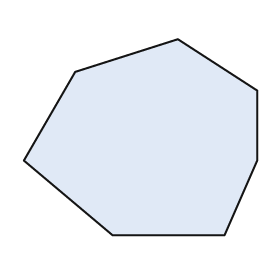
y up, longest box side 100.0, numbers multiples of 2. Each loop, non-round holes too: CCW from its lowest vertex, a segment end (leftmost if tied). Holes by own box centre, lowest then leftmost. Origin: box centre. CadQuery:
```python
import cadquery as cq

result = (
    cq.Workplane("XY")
    .moveTo(-12.0, -42.0)
    .lineTo(36.0, -42.0)
    .lineTo(50.0, -10.0)
    .lineTo(50.0, 20.0)
    .lineTo(16.0, 42.0)
    .lineTo(-28.0, 28.0)
    .lineTo(-50.0, -10.0)
    .close()
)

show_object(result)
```